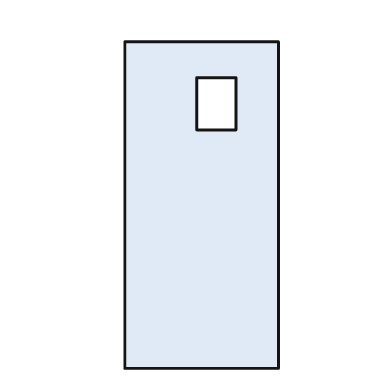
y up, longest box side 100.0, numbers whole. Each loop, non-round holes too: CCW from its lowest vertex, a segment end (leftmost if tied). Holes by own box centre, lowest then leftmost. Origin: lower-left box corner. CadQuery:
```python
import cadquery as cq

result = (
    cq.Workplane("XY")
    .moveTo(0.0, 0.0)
    .lineTo(47.0, 0.0)
    .lineTo(47.0, 100.0)
    .lineTo(0.0, 100.0)
    .close()
    .moveTo(22.0, 73.0)
    .lineTo(34.0, 73.0)
    .lineTo(34.0, 89.0)
    .lineTo(22.0, 89.0)
    .close()
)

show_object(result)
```